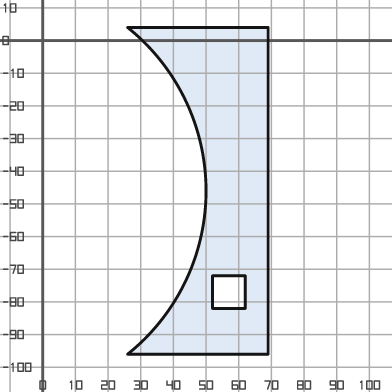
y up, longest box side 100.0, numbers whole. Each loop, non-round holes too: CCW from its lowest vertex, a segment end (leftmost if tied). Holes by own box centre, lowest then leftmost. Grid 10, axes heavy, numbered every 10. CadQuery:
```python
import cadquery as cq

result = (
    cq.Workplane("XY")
    .moveTo(26.0, -96.0)
    .lineTo(69.0, -96.0)
    .lineTo(69.0, 4.0)
    .lineTo(26.0, 4.0)
    .threePointArc((50.0, -46.0), (26.0, -96.0))
    .close()
    .moveTo(52.0, -82.0)
    .lineTo(62.0, -82.0)
    .lineTo(62.0, -72.0)
    .lineTo(52.0, -72.0)
    .close()
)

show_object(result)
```